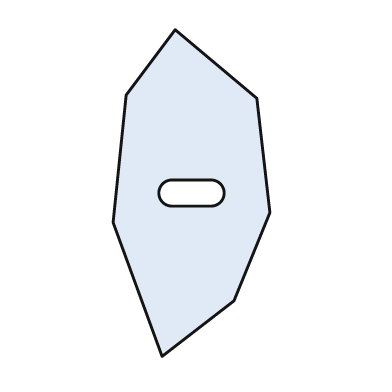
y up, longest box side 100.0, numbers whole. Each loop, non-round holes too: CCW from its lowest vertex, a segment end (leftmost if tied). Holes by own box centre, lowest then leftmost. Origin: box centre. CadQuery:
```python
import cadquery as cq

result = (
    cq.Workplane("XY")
    .moveTo(-9.0, -50.0)
    .lineTo(13.0, -33.0)
    .lineTo(24.0, -6.0)
    .lineTo(20.0, 29.0)
    .lineTo(-5.0, 50.0)
    .lineTo(-20.0, 30.0)
    .lineTo(-24.0, -9.0)
    .close()
    .moveTo(-6.0, -4.0)
    .lineTo(6.0, -4.0)
    .threePointArc((10.0, 0.0), (6.0, 4.0))
    .lineTo(-6.0, 4.0)
    .threePointArc((-10.0, 0.0), (-6.0, -4.0))
    .close()
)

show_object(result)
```